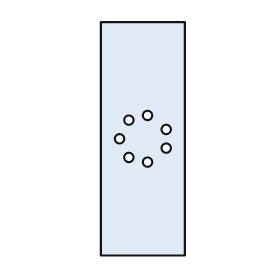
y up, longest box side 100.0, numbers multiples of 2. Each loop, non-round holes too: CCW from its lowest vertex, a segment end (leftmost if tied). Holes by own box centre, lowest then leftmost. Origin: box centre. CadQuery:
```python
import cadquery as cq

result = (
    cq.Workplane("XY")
    .moveTo(-18.0, -50.0)
    .lineTo(18.0, -50.0)
    .lineTo(18.0, 50.0)
    .lineTo(-18.0, 50.0)
    .close()
    .moveTo(2.0, -10.0)
    .circle(2.0)
    .moveTo(-6.0, -8.0)
    .circle(2.0)
    .moveTo(10.0, -4.0)
    .circle(2.0)
    .moveTo(-10.0, 0.0)
    .circle(2.0)
    .moveTo(10.0, 4.0)
    .circle(2.0)
    .moveTo(-6.0, 8.0)
    .circle(2.0)
    .moveTo(2.0, 10.0)
    .circle(2.0)
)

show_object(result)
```